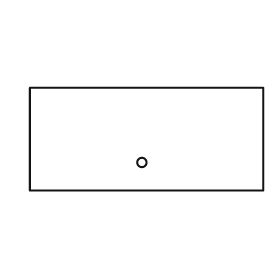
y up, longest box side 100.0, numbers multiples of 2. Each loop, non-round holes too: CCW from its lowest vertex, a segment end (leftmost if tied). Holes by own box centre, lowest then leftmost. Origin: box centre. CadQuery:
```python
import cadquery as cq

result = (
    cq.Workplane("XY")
    .moveTo(-50.0, -22.0)
    .lineTo(50.0, -22.0)
    .lineTo(50.0, 22.0)
    .lineTo(-50.0, 22.0)
    .close()
    .moveTo(-2.0, -10.0)
    .circle(2.0)
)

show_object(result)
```